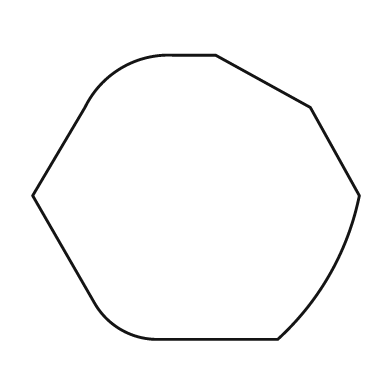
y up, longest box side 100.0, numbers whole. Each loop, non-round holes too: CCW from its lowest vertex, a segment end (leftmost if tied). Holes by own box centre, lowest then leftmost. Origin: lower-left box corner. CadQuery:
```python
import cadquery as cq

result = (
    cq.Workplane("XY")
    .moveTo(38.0, 0.0)
    .lineTo(75.0, 0.0)
    .threePointArc((91.0, 20.0), (100.0, 44.0))
    .lineTo(85.0, 71.0)
    .lineTo(56.0, 87.0)
    .lineTo(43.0, 87.0)
    .threePointArc((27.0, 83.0), (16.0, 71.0))
    .lineTo(0.0, 44.0)
    .lineTo(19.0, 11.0)
    .threePointArc((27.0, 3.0), (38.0, 0.0))
    .close()
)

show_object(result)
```